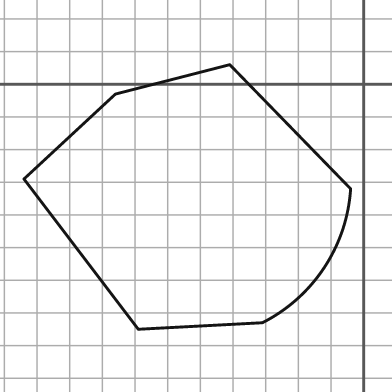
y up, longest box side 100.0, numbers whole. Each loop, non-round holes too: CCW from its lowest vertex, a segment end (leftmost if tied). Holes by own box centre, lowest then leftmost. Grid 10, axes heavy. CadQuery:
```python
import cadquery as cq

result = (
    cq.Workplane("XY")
    .moveTo(-69.0, -75.0)
    .lineTo(-31.0, -73.0)
    .threePointArc((-12.0, -56.0), (-4.0, -32.0))
    .lineTo(-41.0, 6.0)
    .lineTo(-76.0, -3.0)
    .lineTo(-104.0, -29.0)
    .close()
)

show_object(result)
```